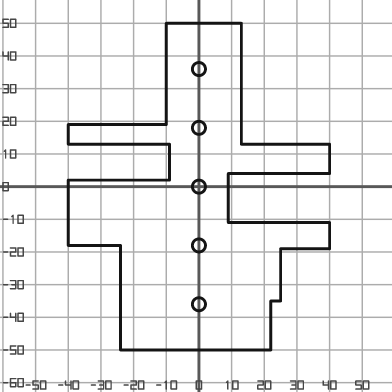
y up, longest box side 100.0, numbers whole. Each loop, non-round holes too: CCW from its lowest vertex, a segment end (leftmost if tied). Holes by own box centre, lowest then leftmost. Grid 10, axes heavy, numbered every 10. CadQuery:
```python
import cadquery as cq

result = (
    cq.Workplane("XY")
    .moveTo(-24.0, -50.0)
    .lineTo(22.0, -50.0)
    .lineTo(22.0, -35.0)
    .lineTo(25.0, -35.0)
    .lineTo(25.0, -19.0)
    .lineTo(40.0, -19.0)
    .lineTo(40.0, -11.0)
    .lineTo(9.0, -11.0)
    .lineTo(9.0, 4.0)
    .lineTo(40.0, 4.0)
    .lineTo(40.0, 13.0)
    .lineTo(13.0, 13.0)
    .lineTo(13.0, 50.0)
    .lineTo(-10.0, 50.0)
    .lineTo(-10.0, 19.0)
    .lineTo(-40.0, 19.0)
    .lineTo(-40.0, 13.0)
    .lineTo(-9.0, 13.0)
    .lineTo(-9.0, 2.0)
    .lineTo(-40.0, 2.0)
    .lineTo(-40.0, -18.0)
    .lineTo(-24.0, -18.0)
    .close()
    .moveTo(0.0, -36.0)
    .circle(2.0)
    .moveTo(0.0, -18.0)
    .circle(2.0)
    .moveTo(0.0, 0.0)
    .circle(2.0)
    .moveTo(0.0, 18.0)
    .circle(2.0)
    .moveTo(0.0, 36.0)
    .circle(2.0)
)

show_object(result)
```